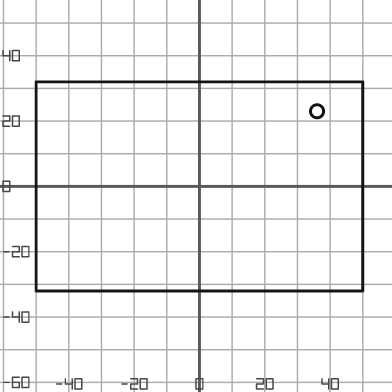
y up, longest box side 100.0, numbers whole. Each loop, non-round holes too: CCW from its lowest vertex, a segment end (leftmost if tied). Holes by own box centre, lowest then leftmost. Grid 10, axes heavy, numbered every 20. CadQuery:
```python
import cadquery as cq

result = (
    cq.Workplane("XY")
    .moveTo(-50.0, -32.0)
    .lineTo(50.0, -32.0)
    .lineTo(50.0, 32.0)
    .lineTo(-50.0, 32.0)
    .close()
    .moveTo(36.0, 23.0)
    .circle(2.0)
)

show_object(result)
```